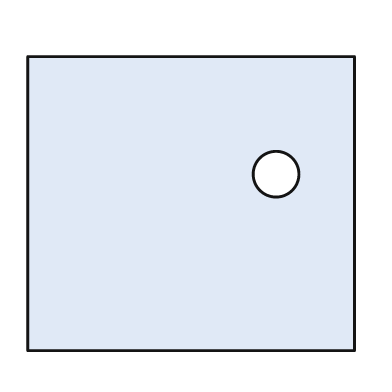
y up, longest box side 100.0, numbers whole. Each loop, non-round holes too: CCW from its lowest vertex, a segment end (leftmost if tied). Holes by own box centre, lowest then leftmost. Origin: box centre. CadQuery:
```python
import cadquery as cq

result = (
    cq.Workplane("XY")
    .moveTo(-50.0, -45.0)
    .lineTo(50.0, -45.0)
    .lineTo(50.0, 45.0)
    .lineTo(-50.0, 45.0)
    .close()
    .moveTo(26.0, 9.0)
    .circle(7.0)
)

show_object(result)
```